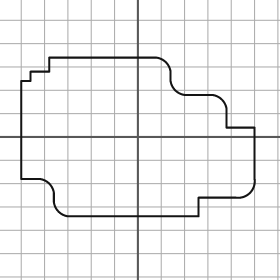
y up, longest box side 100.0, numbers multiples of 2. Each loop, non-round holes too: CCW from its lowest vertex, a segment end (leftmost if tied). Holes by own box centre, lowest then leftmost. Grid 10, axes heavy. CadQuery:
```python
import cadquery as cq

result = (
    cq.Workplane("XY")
    .moveTo(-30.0, -34.0)
    .lineTo(26.0, -34.0)
    .lineTo(26.0, -26.0)
    .lineTo(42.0, -26.0)
    .threePointArc((48.0, -24.0), (50.0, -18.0))
    .lineTo(50.0, 4.0)
    .lineTo(38.0, 4.0)
    .lineTo(38.0, 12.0)
    .threePointArc((36.0, 16.0), (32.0, 18.0))
    .lineTo(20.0, 18.0)
    .threePointArc((16.0, 20.0), (14.0, 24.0))
    .lineTo(14.0, 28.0)
    .threePointArc((12.0, 32.0), (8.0, 34.0))
    .lineTo(-38.0, 34.0)
    .lineTo(-38.0, 28.0)
    .lineTo(-46.0, 28.0)
    .lineTo(-46.0, 24.0)
    .lineTo(-50.0, 24.0)
    .lineTo(-50.0, -18.0)
    .lineTo(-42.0, -18.0)
    .threePointArc((-38.0, -20.0), (-36.0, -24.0))
    .lineTo(-36.0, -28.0)
    .threePointArc((-34.0, -32.0), (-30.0, -34.0))
    .close()
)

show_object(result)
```